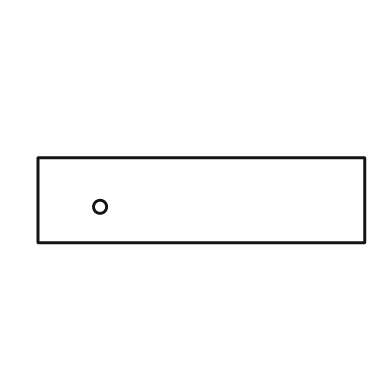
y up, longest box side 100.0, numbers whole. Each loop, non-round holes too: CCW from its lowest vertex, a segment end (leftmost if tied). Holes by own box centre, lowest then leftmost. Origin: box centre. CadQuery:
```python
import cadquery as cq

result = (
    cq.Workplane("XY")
    .moveTo(-50.0, -13.0)
    .lineTo(50.0, -13.0)
    .lineTo(50.0, 13.0)
    .lineTo(-50.0, 13.0)
    .close()
    .moveTo(-31.0, -2.0)
    .circle(2.0)
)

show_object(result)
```